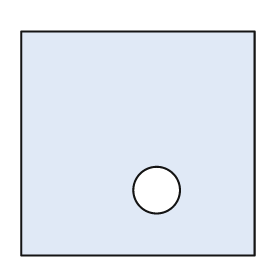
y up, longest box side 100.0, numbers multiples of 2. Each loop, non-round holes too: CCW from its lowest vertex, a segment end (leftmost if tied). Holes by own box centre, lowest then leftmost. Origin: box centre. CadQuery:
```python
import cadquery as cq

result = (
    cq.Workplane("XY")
    .moveTo(-50.0, -48.0)
    .lineTo(50.0, -48.0)
    .lineTo(50.0, 48.0)
    .lineTo(-50.0, 48.0)
    .close()
    .moveTo(8.0, -20.0)
    .circle(10.0)
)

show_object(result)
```